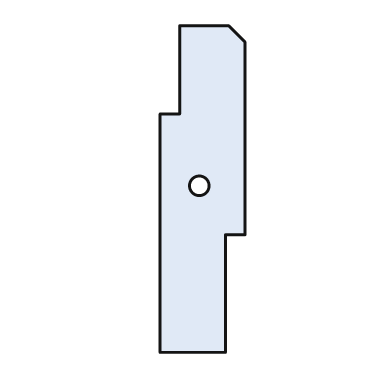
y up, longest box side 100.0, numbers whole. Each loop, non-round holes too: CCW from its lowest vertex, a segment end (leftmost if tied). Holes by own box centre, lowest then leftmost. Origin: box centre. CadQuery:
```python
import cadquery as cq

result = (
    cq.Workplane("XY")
    .moveTo(-13.0, -50.0)
    .lineTo(7.0, -50.0)
    .lineTo(7.0, -14.0)
    .lineTo(13.0, -14.0)
    .lineTo(13.0, 45.0)
    .lineTo(8.0, 50.0)
    .lineTo(-7.0, 50.0)
    .lineTo(-7.0, 23.0)
    .lineTo(-13.0, 23.0)
    .close()
    .moveTo(-1.0, 1.0)
    .circle(3.0)
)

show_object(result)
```